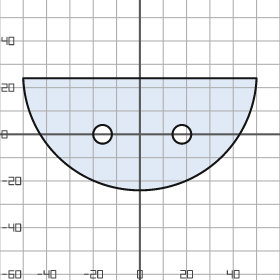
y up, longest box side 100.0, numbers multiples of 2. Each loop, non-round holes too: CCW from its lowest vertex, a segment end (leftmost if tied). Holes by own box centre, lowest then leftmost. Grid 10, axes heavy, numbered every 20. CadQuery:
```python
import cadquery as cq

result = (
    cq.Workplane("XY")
    .moveTo(-50.0, 24.0)
    .threePointArc((0.0, -24.0), (50.0, 24.0))
    .close()
    .moveTo(-16.0, 0.0)
    .circle(4.0)
    .moveTo(18.0, 0.0)
    .circle(4.0)
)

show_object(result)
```